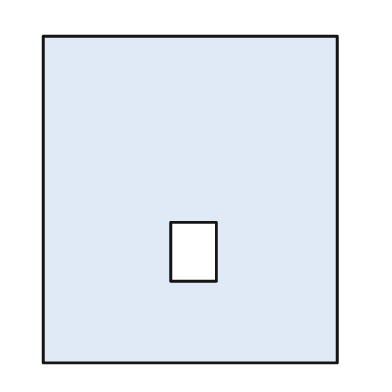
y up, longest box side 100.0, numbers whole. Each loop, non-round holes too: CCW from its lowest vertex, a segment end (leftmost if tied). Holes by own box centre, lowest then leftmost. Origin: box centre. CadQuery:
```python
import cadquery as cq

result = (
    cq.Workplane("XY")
    .moveTo(-45.0, -50.0)
    .lineTo(45.0, -50.0)
    .lineTo(45.0, 50.0)
    .lineTo(-45.0, 50.0)
    .close()
    .moveTo(-6.0, -25.0)
    .lineTo(8.0, -25.0)
    .lineTo(8.0, -7.0)
    .lineTo(-6.0, -7.0)
    .close()
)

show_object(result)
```